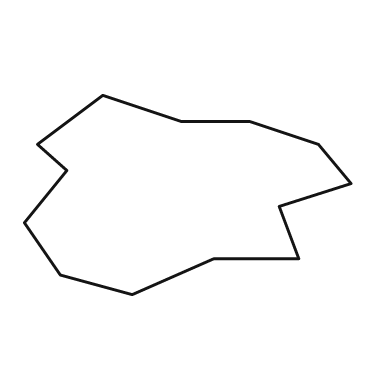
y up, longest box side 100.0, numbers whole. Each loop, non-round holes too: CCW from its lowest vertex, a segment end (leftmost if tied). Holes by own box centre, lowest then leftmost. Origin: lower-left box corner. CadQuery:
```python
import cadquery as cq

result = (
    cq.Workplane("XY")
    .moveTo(33.0, 0.0)
    .lineTo(58.0, 11.0)
    .lineTo(84.0, 11.0)
    .lineTo(78.0, 27.0)
    .lineTo(100.0, 34.0)
    .lineTo(90.0, 46.0)
    .lineTo(69.0, 53.0)
    .lineTo(48.0, 53.0)
    .lineTo(24.0, 61.0)
    .lineTo(4.0, 46.0)
    .lineTo(13.0, 38.0)
    .lineTo(0.0, 22.0)
    .lineTo(11.0, 6.0)
    .close()
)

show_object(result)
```